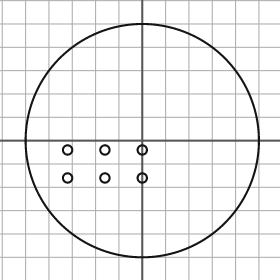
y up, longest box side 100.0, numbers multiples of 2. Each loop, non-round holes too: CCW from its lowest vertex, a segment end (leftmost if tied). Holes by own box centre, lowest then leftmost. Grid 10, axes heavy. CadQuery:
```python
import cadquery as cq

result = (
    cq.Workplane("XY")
    .moveTo(0.0, 0.0)
    .circle(50.0)
    .moveTo(-32.0, -16.0)
    .circle(2.0)
    .moveTo(-16.0, -16.0)
    .circle(2.0)
    .moveTo(0.0, -16.0)
    .circle(2.0)
    .moveTo(-32.0, -4.0)
    .circle(2.0)
    .moveTo(-16.0, -4.0)
    .circle(2.0)
    .moveTo(0.0, -4.0)
    .circle(2.0)
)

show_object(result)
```